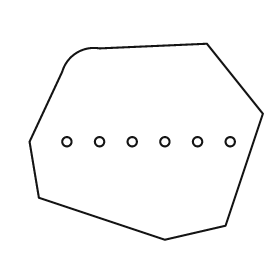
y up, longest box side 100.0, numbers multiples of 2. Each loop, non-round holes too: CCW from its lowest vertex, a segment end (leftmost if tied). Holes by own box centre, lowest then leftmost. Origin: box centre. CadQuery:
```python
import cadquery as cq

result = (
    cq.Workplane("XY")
    .moveTo(8.0, -42.0)
    .lineTo(34.0, -36.0)
    .lineTo(50.0, 12.0)
    .lineTo(26.0, 42.0)
    .lineTo(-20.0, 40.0)
    .threePointArc((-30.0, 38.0), (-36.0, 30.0))
    .lineTo(-50.0, 0.0)
    .lineTo(-46.0, -24.0)
    .close()
    .moveTo(-34.0, 0.0)
    .circle(2.0)
    .moveTo(-20.0, 0.0)
    .circle(2.0)
    .moveTo(-6.0, 0.0)
    .circle(2.0)
    .moveTo(8.0, 0.0)
    .circle(2.0)
    .moveTo(22.0, 0.0)
    .circle(2.0)
    .moveTo(36.0, 0.0)
    .circle(2.0)
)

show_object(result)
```